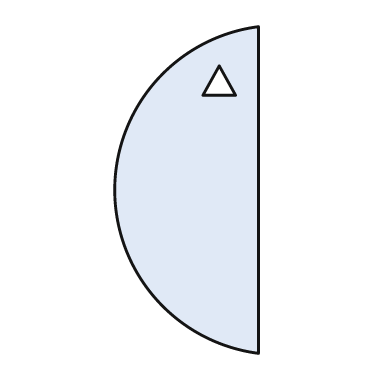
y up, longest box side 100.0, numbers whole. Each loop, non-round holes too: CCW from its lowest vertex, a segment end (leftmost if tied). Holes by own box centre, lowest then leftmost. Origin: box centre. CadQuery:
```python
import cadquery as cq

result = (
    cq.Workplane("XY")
    .moveTo(22.0, -50.0)
    .lineTo(22.0, 50.0)
    .threePointArc((-22.0, 0.0), (22.0, -50.0))
    .close()
    .moveTo(5.0, 29.0)
    .lineTo(15.0, 29.0)
    .lineTo(10.0, 38.0)
    .close()
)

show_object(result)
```